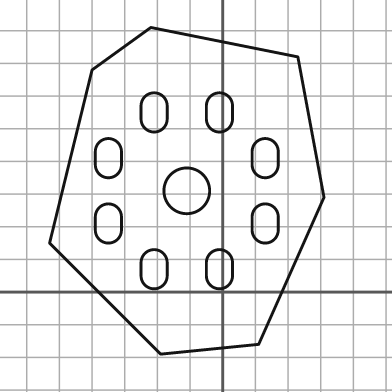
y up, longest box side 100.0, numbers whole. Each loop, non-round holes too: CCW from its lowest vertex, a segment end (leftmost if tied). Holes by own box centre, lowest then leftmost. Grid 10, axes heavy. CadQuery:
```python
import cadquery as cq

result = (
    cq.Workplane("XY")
    .moveTo(-19.0, -19.0)
    .lineTo(11.0, -16.0)
    .lineTo(31.0, 29.0)
    .lineTo(23.0, 72.0)
    .lineTo(-22.0, 81.0)
    .lineTo(-40.0, 68.0)
    .lineTo(-53.0, 15.0)
    .close()
    .moveTo(-25.0, 5.0)
    .threePointArc((-21.0, 1.0), (-17.0, 5.0))
    .lineTo(-17.0, 9.0)
    .threePointArc((-21.0, 13.0), (-25.0, 9.0))
    .close()
    .moveTo(-5.0, 5.0)
    .threePointArc((-1.0, 1.0), (3.0, 5.0))
    .lineTo(3.0, 9.0)
    .threePointArc((-1.0, 13.0), (-5.0, 9.0))
    .close()
    .moveTo(-39.0, 19.0)
    .threePointArc((-35.0, 15.0), (-31.0, 19.0))
    .lineTo(-31.0, 23.0)
    .threePointArc((-35.0, 27.0), (-39.0, 23.0))
    .close()
    .moveTo(9.0, 19.0)
    .threePointArc((13.0, 15.0), (17.0, 19.0))
    .lineTo(17.0, 23.0)
    .threePointArc((13.0, 27.0), (9.0, 23.0))
    .close()
    .moveTo(-11.0, 31.0)
    .circle(7.0)
    .moveTo(-39.0, 39.0)
    .threePointArc((-35.0, 35.0), (-31.0, 39.0))
    .lineTo(-31.0, 43.0)
    .threePointArc((-35.0, 47.0), (-39.0, 43.0))
    .close()
    .moveTo(9.0, 39.0)
    .threePointArc((13.0, 35.0), (17.0, 39.0))
    .lineTo(17.0, 43.0)
    .threePointArc((13.0, 47.0), (9.0, 43.0))
    .close()
    .moveTo(-25.0, 53.0)
    .threePointArc((-21.0, 49.0), (-17.0, 53.0))
    .lineTo(-17.0, 57.0)
    .threePointArc((-21.0, 61.0), (-25.0, 57.0))
    .close()
    .moveTo(-5.0, 53.0)
    .threePointArc((-1.0, 49.0), (3.0, 53.0))
    .lineTo(3.0, 57.0)
    .threePointArc((-1.0, 61.0), (-5.0, 57.0))
    .close()
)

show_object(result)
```